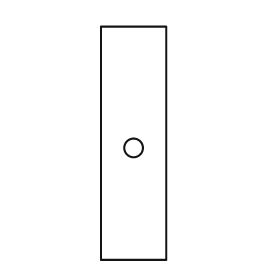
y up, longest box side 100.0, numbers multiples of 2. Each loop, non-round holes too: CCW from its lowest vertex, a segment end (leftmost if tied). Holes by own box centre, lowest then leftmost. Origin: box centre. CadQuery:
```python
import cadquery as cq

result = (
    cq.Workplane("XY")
    .moveTo(-14.0, -50.0)
    .lineTo(14.0, -50.0)
    .lineTo(14.0, 50.0)
    .lineTo(-14.0, 50.0)
    .close()
    .moveTo(0.0, -2.0)
    .circle(4.0)
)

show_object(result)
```